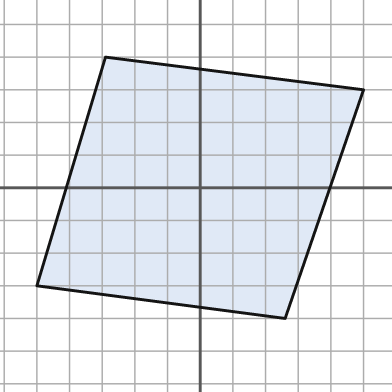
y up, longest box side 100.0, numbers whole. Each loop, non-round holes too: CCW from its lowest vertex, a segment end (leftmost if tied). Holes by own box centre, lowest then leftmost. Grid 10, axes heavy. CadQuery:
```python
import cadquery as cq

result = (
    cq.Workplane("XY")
    .moveTo(26.0, -40.0)
    .lineTo(50.0, 30.0)
    .lineTo(-29.0, 40.0)
    .lineTo(-50.0, -30.0)
    .close()
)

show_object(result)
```